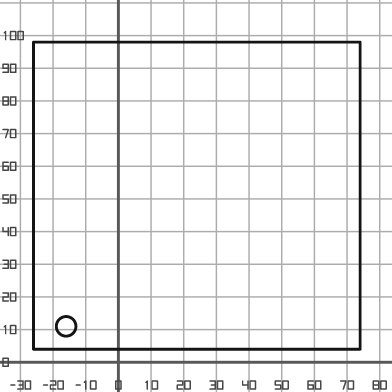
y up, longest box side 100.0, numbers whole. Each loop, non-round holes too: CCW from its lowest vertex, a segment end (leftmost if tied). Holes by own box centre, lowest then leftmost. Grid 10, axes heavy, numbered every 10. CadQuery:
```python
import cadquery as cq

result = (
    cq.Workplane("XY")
    .moveTo(-26.0, 4.0)
    .lineTo(74.0, 4.0)
    .lineTo(74.0, 98.0)
    .lineTo(-26.0, 98.0)
    .close()
    .moveTo(-16.0, 11.0)
    .circle(3.0)
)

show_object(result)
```